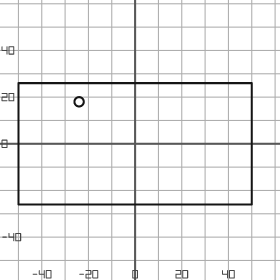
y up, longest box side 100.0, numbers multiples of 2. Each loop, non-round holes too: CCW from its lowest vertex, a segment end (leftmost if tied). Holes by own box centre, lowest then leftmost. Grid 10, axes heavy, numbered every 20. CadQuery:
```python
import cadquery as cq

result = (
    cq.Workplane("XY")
    .moveTo(-50.0, -26.0)
    .lineTo(50.0, -26.0)
    .lineTo(50.0, 26.0)
    .lineTo(-50.0, 26.0)
    .close()
    .moveTo(-24.0, 18.0)
    .circle(2.0)
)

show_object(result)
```